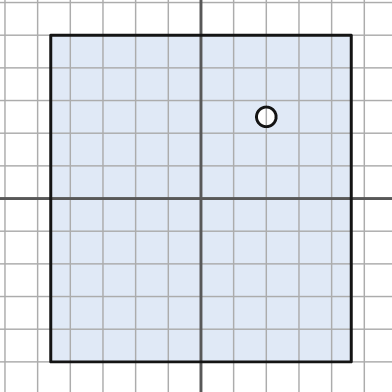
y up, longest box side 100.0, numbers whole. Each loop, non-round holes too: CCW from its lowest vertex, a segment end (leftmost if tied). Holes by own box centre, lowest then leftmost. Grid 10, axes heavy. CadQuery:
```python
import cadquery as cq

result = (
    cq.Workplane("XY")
    .moveTo(-46.0, -50.0)
    .lineTo(46.0, -50.0)
    .lineTo(46.0, 50.0)
    .lineTo(-46.0, 50.0)
    .close()
    .moveTo(20.0, 25.0)
    .circle(3.0)
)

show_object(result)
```